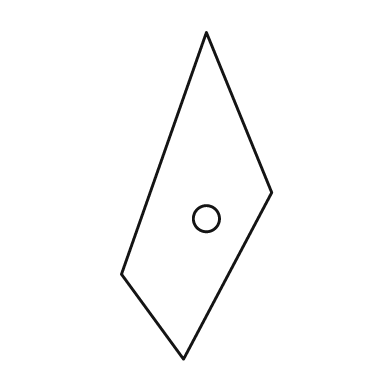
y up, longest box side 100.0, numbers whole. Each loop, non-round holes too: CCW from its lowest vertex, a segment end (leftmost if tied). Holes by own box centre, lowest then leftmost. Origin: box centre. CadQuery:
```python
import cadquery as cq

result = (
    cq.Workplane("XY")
    .moveTo(-4.0, -50.0)
    .lineTo(23.0, 1.0)
    .lineTo(3.0, 50.0)
    .lineTo(-23.0, -24.0)
    .close()
    .moveTo(3.0, -7.0)
    .circle(4.0)
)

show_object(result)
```